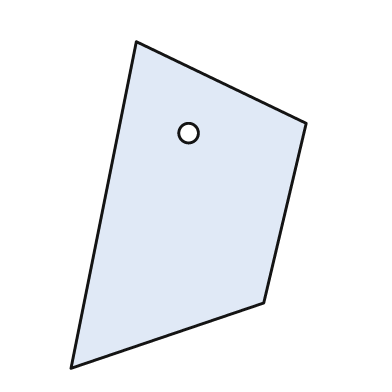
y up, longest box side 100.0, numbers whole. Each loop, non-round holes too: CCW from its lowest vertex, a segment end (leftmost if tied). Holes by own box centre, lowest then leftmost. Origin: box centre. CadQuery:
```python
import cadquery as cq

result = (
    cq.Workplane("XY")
    .moveTo(-36.0, -50.0)
    .lineTo(23.0, -30.0)
    .lineTo(36.0, 25.0)
    .lineTo(-16.0, 50.0)
    .close()
    .moveTo(0.0, 22.0)
    .circle(3.0)
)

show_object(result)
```